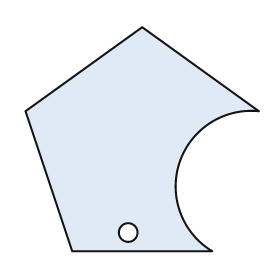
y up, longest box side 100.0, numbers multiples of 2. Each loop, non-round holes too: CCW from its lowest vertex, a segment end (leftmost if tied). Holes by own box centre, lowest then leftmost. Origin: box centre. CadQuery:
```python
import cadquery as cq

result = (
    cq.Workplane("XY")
    .moveTo(-30.0, -48.0)
    .lineTo(30.0, -48.0)
    .threePointArc((16.0, -10.0), (50.0, 12.0))
    .lineTo(0.0, 48.0)
    .lineTo(-50.0, 12.0)
    .close()
    .moveTo(-6.0, -40.0)
    .circle(4.0)
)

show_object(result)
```